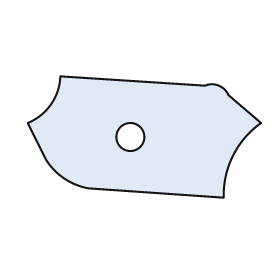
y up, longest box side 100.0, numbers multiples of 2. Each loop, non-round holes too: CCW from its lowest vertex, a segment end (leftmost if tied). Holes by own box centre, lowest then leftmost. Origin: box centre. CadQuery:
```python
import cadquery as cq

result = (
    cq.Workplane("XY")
    .moveTo(34.0, -26.0)
    .threePointArc((38.0, -8.0), (50.0, 6.0))
    .lineTo(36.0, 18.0)
    .threePointArc((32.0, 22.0), (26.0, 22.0))
    .lineTo(-36.0, 26.0)
    .threePointArc((-40.0, 14.0), (-50.0, 6.0))
    .lineTo(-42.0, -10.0)
    .threePointArc((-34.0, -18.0), (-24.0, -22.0))
    .close()
    .moveTo(-6.0, 0.0)
    .circle(6.0)
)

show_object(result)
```